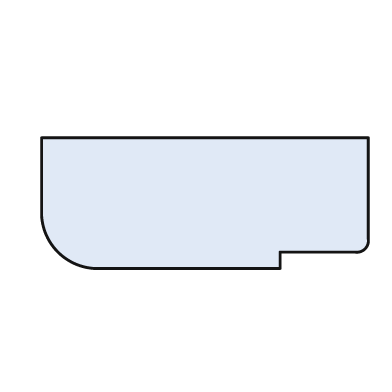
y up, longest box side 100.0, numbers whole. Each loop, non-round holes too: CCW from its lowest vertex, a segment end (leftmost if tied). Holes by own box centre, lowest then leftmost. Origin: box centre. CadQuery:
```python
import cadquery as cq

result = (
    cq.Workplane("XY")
    .moveTo(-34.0, -20.0)
    .lineTo(23.0, -20.0)
    .lineTo(23.0, -15.0)
    .lineTo(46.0, -15.0)
    .threePointArc((49.0, -14.0), (50.0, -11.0))
    .lineTo(50.0, 20.0)
    .lineTo(-50.0, 20.0)
    .lineTo(-50.0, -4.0)
    .threePointArc((-45.0, -15.0), (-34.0, -20.0))
    .close()
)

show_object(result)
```